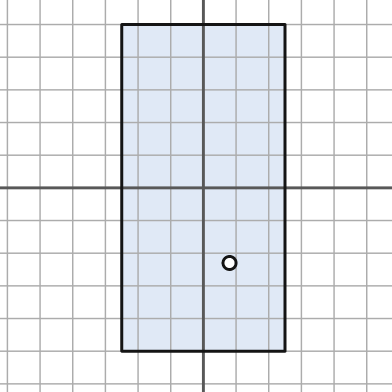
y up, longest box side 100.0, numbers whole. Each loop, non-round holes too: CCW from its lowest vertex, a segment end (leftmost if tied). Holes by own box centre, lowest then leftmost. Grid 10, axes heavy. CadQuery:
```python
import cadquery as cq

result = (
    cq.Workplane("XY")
    .moveTo(-25.0, -50.0)
    .lineTo(25.0, -50.0)
    .lineTo(25.0, 50.0)
    .lineTo(-25.0, 50.0)
    .close()
    .moveTo(8.0, -23.0)
    .circle(2.0)
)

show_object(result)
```